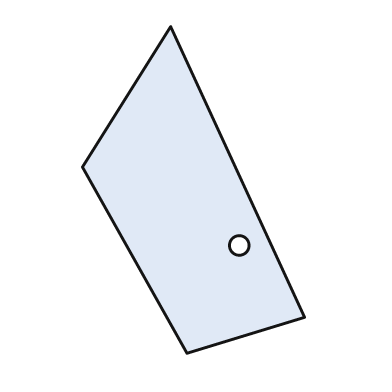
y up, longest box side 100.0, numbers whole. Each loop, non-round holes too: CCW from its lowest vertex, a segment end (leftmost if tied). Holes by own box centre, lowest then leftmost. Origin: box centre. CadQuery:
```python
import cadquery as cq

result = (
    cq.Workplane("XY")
    .moveTo(-2.0, -50.0)
    .lineTo(34.0, -39.0)
    .lineTo(-7.0, 50.0)
    .lineTo(-34.0, 7.0)
    .close()
    .moveTo(14.0, -17.0)
    .circle(3.0)
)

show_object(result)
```